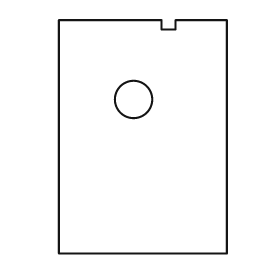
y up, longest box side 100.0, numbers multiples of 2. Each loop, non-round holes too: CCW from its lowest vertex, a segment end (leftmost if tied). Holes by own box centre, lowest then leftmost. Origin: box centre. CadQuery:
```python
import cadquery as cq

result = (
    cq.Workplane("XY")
    .moveTo(-36.0, -50.0)
    .lineTo(36.0, -50.0)
    .lineTo(36.0, 50.0)
    .lineTo(14.0, 50.0)
    .lineTo(14.0, 46.0)
    .lineTo(8.0, 46.0)
    .lineTo(8.0, 50.0)
    .lineTo(-36.0, 50.0)
    .close()
    .moveTo(-4.0, 16.0)
    .circle(8.0)
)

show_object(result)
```